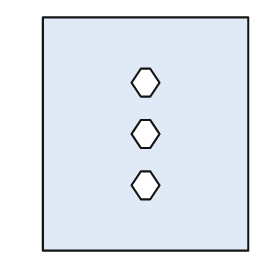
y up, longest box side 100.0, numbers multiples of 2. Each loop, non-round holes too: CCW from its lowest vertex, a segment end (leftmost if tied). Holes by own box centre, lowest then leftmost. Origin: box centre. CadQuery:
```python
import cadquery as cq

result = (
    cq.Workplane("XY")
    .moveTo(-44.0, -50.0)
    .lineTo(44.0, -50.0)
    .lineTo(44.0, 50.0)
    .lineTo(-44.0, 50.0)
    .close()
    .moveTo(-2.0, -28.0)
    .lineTo(2.0, -28.0)
    .lineTo(6.0, -22.0)
    .lineTo(2.0, -16.0)
    .lineTo(-2.0, -16.0)
    .lineTo(-6.0, -22.0)
    .close()
    .moveTo(-2.0, -6.0)
    .lineTo(2.0, -6.0)
    .lineTo(6.0, 0.0)
    .lineTo(2.0, 6.0)
    .lineTo(-2.0, 6.0)
    .lineTo(-6.0, 0.0)
    .close()
    .moveTo(-2.0, 16.0)
    .lineTo(2.0, 16.0)
    .lineTo(6.0, 22.0)
    .lineTo(2.0, 28.0)
    .lineTo(-2.0, 28.0)
    .lineTo(-6.0, 22.0)
    .close()
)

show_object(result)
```